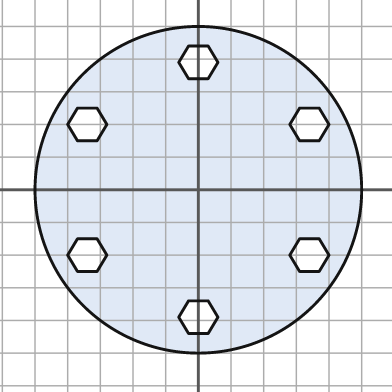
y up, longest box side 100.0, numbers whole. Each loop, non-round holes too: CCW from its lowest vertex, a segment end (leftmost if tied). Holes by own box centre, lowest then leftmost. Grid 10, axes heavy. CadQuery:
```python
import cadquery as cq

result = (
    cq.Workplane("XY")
    .moveTo(0.0, 0.0)
    .circle(50.0)
    .moveTo(-3.0, -44.0)
    .lineTo(3.0, -44.0)
    .lineTo(6.0, -39.0)
    .lineTo(3.0, -34.0)
    .lineTo(-3.0, -34.0)
    .lineTo(-6.0, -39.0)
    .close()
    .moveTo(-37.0, -25.0)
    .lineTo(-31.0, -25.0)
    .lineTo(-28.0, -20.0)
    .lineTo(-31.0, -15.0)
    .lineTo(-37.0, -15.0)
    .lineTo(-40.0, -20.0)
    .close()
    .moveTo(31.0, -25.0)
    .lineTo(37.0, -25.0)
    .lineTo(40.0, -20.0)
    .lineTo(37.0, -15.0)
    .lineTo(31.0, -15.0)
    .lineTo(28.0, -20.0)
    .close()
    .moveTo(-37.0, 15.0)
    .lineTo(-31.0, 15.0)
    .lineTo(-28.0, 20.0)
    .lineTo(-31.0, 25.0)
    .lineTo(-37.0, 25.0)
    .lineTo(-40.0, 20.0)
    .close()
    .moveTo(31.0, 15.0)
    .lineTo(37.0, 15.0)
    .lineTo(40.0, 20.0)
    .lineTo(37.0, 25.0)
    .lineTo(31.0, 25.0)
    .lineTo(28.0, 20.0)
    .close()
    .moveTo(-3.0, 34.0)
    .lineTo(3.0, 34.0)
    .lineTo(6.0, 39.0)
    .lineTo(3.0, 44.0)
    .lineTo(-3.0, 44.0)
    .lineTo(-6.0, 39.0)
    .close()
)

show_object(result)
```